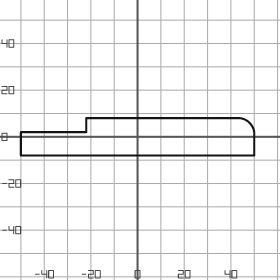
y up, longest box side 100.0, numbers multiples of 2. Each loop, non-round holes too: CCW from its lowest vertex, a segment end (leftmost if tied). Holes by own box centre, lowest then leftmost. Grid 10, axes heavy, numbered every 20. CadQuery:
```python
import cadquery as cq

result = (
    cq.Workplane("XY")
    .moveTo(-50.0, -8.0)
    .lineTo(50.0, -8.0)
    .lineTo(50.0, 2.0)
    .threePointArc((48.0, 6.0), (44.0, 8.0))
    .lineTo(-22.0, 8.0)
    .lineTo(-22.0, 2.0)
    .lineTo(-50.0, 2.0)
    .close()
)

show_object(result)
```